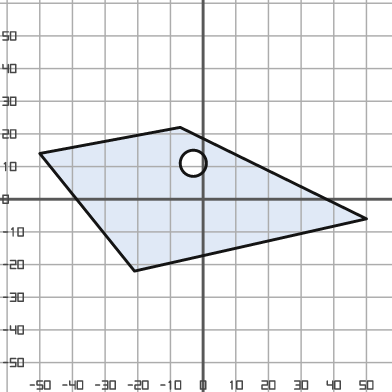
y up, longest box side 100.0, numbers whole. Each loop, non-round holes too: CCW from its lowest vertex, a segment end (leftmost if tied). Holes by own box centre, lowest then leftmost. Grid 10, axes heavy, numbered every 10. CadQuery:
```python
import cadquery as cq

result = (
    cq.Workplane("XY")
    .moveTo(-21.0, -22.0)
    .lineTo(50.0, -6.0)
    .lineTo(-7.0, 22.0)
    .lineTo(-50.0, 14.0)
    .close()
    .moveTo(-3.0, 11.0)
    .circle(4.0)
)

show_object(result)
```